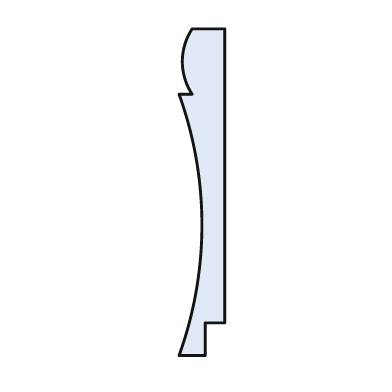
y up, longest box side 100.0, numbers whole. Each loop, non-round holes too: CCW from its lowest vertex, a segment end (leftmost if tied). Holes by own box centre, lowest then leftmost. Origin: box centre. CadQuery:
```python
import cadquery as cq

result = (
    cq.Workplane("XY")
    .moveTo(-7.0, -50.0)
    .lineTo(1.0, -50.0)
    .lineTo(1.0, -40.0)
    .lineTo(7.0, -40.0)
    .lineTo(7.0, 50.0)
    .lineTo(-3.0, 50.0)
    .threePointArc((-6.0, 40.0), (-3.0, 30.0))
    .lineTo(-7.0, 30.0)
    .threePointArc((0.0, -10.0), (-7.0, -50.0))
    .close()
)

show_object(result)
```